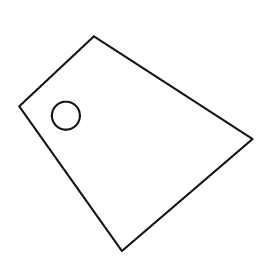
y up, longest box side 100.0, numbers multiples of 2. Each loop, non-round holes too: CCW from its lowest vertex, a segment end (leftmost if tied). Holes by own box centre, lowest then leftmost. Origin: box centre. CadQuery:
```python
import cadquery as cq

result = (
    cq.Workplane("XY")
    .moveTo(-6.0, -46.0)
    .lineTo(50.0, 2.0)
    .lineTo(-18.0, 46.0)
    .lineTo(-50.0, 16.0)
    .close()
    .moveTo(-30.0, 12.0)
    .circle(6.0)
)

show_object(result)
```